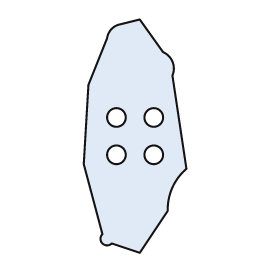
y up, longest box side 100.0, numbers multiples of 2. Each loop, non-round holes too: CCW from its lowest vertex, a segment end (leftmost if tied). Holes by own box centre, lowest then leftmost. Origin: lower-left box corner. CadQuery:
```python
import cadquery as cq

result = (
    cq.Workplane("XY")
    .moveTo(24.0, 0.0)
    .lineTo(36.0, 18.0)
    .threePointArc((38.0, 28.0), (44.0, 36.0))
    .lineTo(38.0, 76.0)
    .threePointArc((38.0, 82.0), (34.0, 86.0))
    .lineTo(24.0, 100.0)
    .lineTo(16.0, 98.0)
    .threePointArc((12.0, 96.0), (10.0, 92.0))
    .lineTo(2.0, 72.0)
    .lineTo(0.0, 38.0)
    .lineTo(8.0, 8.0)
    .threePointArc((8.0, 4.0), (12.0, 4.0))
    .close()
    .moveTo(14.0, 42.0)
    .circle(4.0)
    .moveTo(30.0, 42.0)
    .circle(4.0)
    .moveTo(14.0, 58.0)
    .circle(4.0)
    .moveTo(30.0, 58.0)
    .circle(4.0)
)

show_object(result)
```